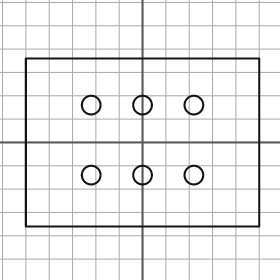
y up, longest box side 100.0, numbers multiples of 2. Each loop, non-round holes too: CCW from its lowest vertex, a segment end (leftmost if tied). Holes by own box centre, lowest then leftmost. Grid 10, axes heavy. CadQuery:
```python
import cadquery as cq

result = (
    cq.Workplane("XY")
    .moveTo(-50.0, -36.0)
    .lineTo(50.0, -36.0)
    .lineTo(50.0, 36.0)
    .lineTo(-50.0, 36.0)
    .close()
    .moveTo(-22.0, -14.0)
    .circle(4.0)
    .moveTo(0.0, -14.0)
    .circle(4.0)
    .moveTo(22.0, -14.0)
    .circle(4.0)
    .moveTo(-22.0, 16.0)
    .circle(4.0)
    .moveTo(0.0, 16.0)
    .circle(4.0)
    .moveTo(22.0, 16.0)
    .circle(4.0)
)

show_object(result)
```